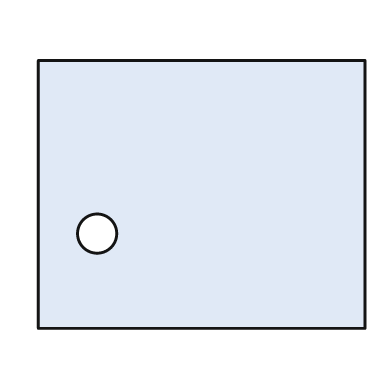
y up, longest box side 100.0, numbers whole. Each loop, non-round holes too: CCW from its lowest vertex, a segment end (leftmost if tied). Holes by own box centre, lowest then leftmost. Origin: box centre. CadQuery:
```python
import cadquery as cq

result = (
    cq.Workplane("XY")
    .moveTo(-50.0, -41.0)
    .lineTo(50.0, -41.0)
    .lineTo(50.0, 41.0)
    .lineTo(-50.0, 41.0)
    .close()
    .moveTo(-32.0, -12.0)
    .circle(6.0)
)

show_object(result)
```